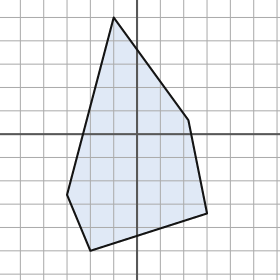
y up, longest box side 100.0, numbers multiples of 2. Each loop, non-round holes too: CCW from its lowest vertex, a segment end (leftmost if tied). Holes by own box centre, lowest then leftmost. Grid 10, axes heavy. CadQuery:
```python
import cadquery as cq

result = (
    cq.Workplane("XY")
    .moveTo(-20.0, -50.0)
    .lineTo(30.0, -34.0)
    .lineTo(22.0, 6.0)
    .lineTo(-10.0, 50.0)
    .lineTo(-30.0, -26.0)
    .close()
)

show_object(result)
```